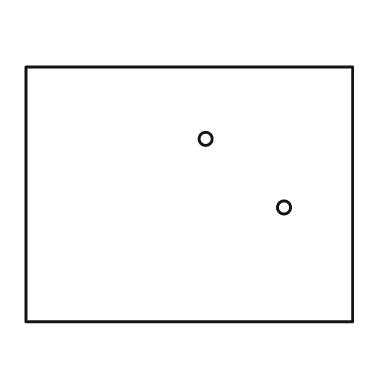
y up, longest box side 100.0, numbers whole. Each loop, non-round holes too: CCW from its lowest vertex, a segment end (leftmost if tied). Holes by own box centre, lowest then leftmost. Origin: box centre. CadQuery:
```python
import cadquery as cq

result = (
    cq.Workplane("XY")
    .moveTo(-50.0, -39.0)
    .lineTo(50.0, -39.0)
    .lineTo(50.0, 39.0)
    .lineTo(-50.0, 39.0)
    .close()
    .moveTo(29.0, -4.0)
    .circle(2.0)
    .moveTo(5.0, 17.0)
    .circle(2.0)
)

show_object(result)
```